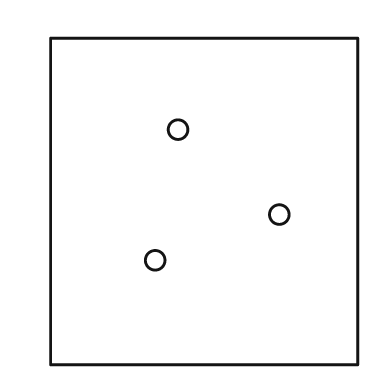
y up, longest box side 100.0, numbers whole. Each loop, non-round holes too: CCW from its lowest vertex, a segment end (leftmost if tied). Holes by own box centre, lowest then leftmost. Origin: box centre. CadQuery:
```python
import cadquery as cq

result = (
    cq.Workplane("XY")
    .moveTo(-47.0, -50.0)
    .lineTo(47.0, -50.0)
    .lineTo(47.0, 50.0)
    .lineTo(-47.0, 50.0)
    .close()
    .moveTo(-15.0, -18.0)
    .circle(3.0)
    .moveTo(23.0, -4.0)
    .circle(3.0)
    .moveTo(-8.0, 22.0)
    .circle(3.0)
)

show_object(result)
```